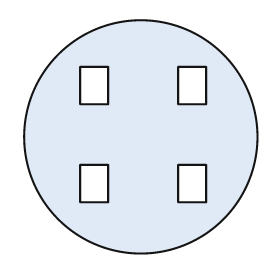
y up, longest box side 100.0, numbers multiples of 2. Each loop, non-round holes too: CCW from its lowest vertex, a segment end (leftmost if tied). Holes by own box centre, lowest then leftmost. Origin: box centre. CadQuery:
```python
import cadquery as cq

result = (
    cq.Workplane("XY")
    .moveTo(0.0, 0.0)
    .circle(50.0)
    .moveTo(-26.0, -28.0)
    .lineTo(-14.0, -28.0)
    .lineTo(-14.0, -12.0)
    .lineTo(-26.0, -12.0)
    .close()
    .moveTo(16.0, -28.0)
    .lineTo(28.0, -28.0)
    .lineTo(28.0, -12.0)
    .lineTo(16.0, -12.0)
    .close()
    .moveTo(-26.0, 14.0)
    .lineTo(-14.0, 14.0)
    .lineTo(-14.0, 30.0)
    .lineTo(-26.0, 30.0)
    .close()
    .moveTo(16.0, 14.0)
    .lineTo(28.0, 14.0)
    .lineTo(28.0, 30.0)
    .lineTo(16.0, 30.0)
    .close()
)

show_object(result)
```